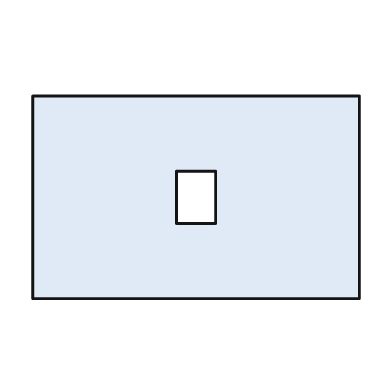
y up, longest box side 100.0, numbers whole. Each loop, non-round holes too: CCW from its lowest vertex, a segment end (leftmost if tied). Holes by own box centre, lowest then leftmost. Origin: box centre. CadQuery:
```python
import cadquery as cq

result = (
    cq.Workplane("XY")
    .moveTo(-50.0, -31.0)
    .lineTo(50.0, -31.0)
    .lineTo(50.0, 31.0)
    .lineTo(-50.0, 31.0)
    .close()
    .moveTo(-6.0, -8.0)
    .lineTo(6.0, -8.0)
    .lineTo(6.0, 8.0)
    .lineTo(-6.0, 8.0)
    .close()
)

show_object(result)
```